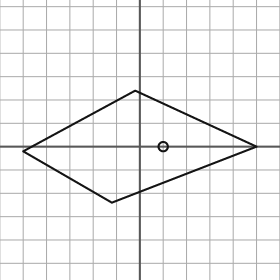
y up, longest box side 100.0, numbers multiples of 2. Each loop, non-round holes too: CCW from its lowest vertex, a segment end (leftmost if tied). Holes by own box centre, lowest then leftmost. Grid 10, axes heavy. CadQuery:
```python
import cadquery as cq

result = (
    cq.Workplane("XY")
    .moveTo(-12.0, -24.0)
    .lineTo(50.0, 0.0)
    .lineTo(-2.0, 24.0)
    .lineTo(-50.0, -2.0)
    .close()
    .moveTo(10.0, 0.0)
    .circle(2.0)
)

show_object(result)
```